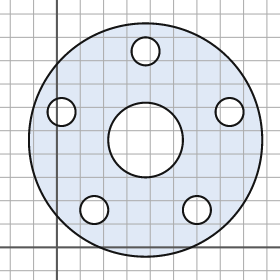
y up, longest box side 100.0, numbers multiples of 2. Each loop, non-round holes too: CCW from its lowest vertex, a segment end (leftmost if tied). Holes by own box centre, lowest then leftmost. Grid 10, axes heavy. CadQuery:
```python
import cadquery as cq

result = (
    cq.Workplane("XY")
    .moveTo(38.0, 46.0)
    .circle(50.0)
    .moveTo(16.0, 16.0)
    .circle(6.0)
    .moveTo(60.0, 16.0)
    .circle(6.0)
    .moveTo(38.0, 46.0)
    .circle(16.0)
    .moveTo(2.0, 58.0)
    .circle(6.0)
    .moveTo(74.0, 58.0)
    .circle(6.0)
    .moveTo(38.0, 84.0)
    .circle(6.0)
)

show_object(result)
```